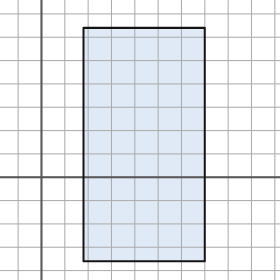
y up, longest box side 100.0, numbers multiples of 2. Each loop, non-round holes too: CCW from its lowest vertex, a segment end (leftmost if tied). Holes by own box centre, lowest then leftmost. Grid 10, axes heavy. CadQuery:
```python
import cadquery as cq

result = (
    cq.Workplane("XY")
    .moveTo(18.0, -36.0)
    .lineTo(70.0, -36.0)
    .lineTo(70.0, 64.0)
    .lineTo(18.0, 64.0)
    .close()
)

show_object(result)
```